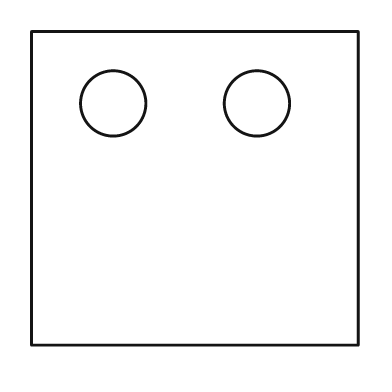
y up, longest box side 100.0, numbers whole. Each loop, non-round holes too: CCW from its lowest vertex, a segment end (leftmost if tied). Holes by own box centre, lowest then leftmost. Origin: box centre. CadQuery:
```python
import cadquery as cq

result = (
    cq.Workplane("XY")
    .moveTo(-50.0, -48.0)
    .lineTo(50.0, -48.0)
    .lineTo(50.0, 48.0)
    .lineTo(-50.0, 48.0)
    .close()
    .moveTo(-25.0, 26.0)
    .circle(10.0)
    .moveTo(19.0, 26.0)
    .circle(10.0)
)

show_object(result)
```